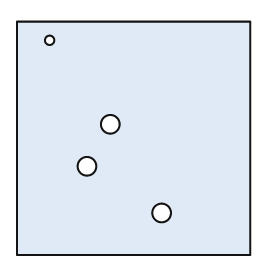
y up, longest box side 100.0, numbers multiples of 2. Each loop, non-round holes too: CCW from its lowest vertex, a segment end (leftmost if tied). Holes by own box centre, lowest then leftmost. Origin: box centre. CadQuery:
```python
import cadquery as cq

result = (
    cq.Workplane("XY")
    .moveTo(-50.0, -50.0)
    .lineTo(50.0, -50.0)
    .lineTo(50.0, 50.0)
    .lineTo(-50.0, 50.0)
    .close()
    .moveTo(12.0, -32.0)
    .circle(4.0)
    .moveTo(-20.0, -12.0)
    .circle(4.0)
    .moveTo(-10.0, 6.0)
    .circle(4.0)
    .moveTo(-36.0, 42.0)
    .circle(2.0)
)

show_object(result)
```